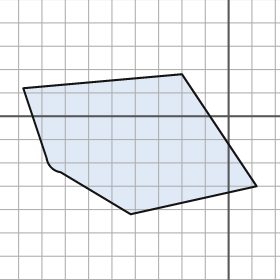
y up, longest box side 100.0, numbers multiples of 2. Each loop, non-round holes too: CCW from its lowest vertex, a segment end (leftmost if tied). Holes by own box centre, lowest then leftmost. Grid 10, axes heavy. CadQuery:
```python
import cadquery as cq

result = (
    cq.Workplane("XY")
    .moveTo(-42.0, -42.0)
    .lineTo(12.0, -30.0)
    .lineTo(-20.0, 18.0)
    .lineTo(-88.0, 12.0)
    .lineTo(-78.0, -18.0)
    .threePointArc((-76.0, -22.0), (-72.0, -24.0))
    .close()
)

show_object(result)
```